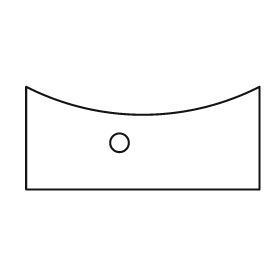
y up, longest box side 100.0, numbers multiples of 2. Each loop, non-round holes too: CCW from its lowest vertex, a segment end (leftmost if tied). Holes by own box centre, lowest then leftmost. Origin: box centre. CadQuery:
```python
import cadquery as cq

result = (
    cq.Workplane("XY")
    .moveTo(-50.0, -22.0)
    .lineTo(50.0, -22.0)
    .lineTo(50.0, 22.0)
    .threePointArc((0.0, 10.0), (-50.0, 22.0))
    .close()
    .moveTo(-10.0, -2.0)
    .circle(4.0)
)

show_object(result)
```